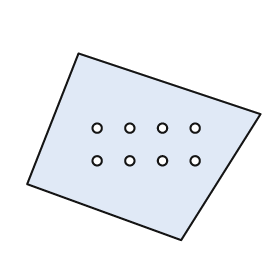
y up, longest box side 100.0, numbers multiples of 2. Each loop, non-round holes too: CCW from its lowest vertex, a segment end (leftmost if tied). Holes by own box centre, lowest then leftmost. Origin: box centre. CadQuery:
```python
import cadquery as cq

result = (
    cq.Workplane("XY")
    .moveTo(16.0, -40.0)
    .lineTo(50.0, 14.0)
    .lineTo(-28.0, 40.0)
    .lineTo(-50.0, -16.0)
    .close()
    .moveTo(-20.0, -6.0)
    .circle(2.0)
    .moveTo(-6.0, -6.0)
    .circle(2.0)
    .moveTo(8.0, -6.0)
    .circle(2.0)
    .moveTo(22.0, -6.0)
    .circle(2.0)
    .moveTo(-20.0, 8.0)
    .circle(2.0)
    .moveTo(-6.0, 8.0)
    .circle(2.0)
    .moveTo(8.0, 8.0)
    .circle(2.0)
    .moveTo(22.0, 8.0)
    .circle(2.0)
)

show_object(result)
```